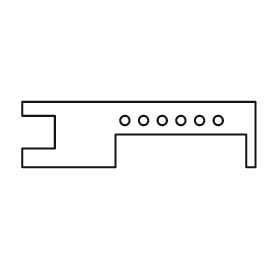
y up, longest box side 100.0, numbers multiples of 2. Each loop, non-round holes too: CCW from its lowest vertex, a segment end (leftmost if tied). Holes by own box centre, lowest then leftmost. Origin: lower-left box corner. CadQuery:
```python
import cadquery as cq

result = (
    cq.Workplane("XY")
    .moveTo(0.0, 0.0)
    .lineTo(40.0, 0.0)
    .lineTo(40.0, 14.0)
    .lineTo(96.0, 14.0)
    .lineTo(96.0, 0.0)
    .lineTo(100.0, 0.0)
    .lineTo(100.0, 28.0)
    .lineTo(0.0, 28.0)
    .lineTo(0.0, 22.0)
    .lineTo(14.0, 22.0)
    .lineTo(14.0, 8.0)
    .lineTo(0.0, 8.0)
    .close()
    .moveTo(44.0, 20.0)
    .circle(2.0)
    .moveTo(52.0, 20.0)
    .circle(2.0)
    .moveTo(60.0, 20.0)
    .circle(2.0)
    .moveTo(68.0, 20.0)
    .circle(2.0)
    .moveTo(76.0, 20.0)
    .circle(2.0)
    .moveTo(84.0, 20.0)
    .circle(2.0)
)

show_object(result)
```